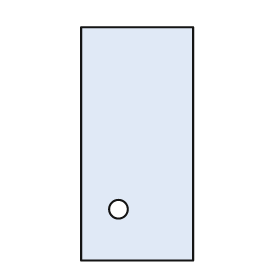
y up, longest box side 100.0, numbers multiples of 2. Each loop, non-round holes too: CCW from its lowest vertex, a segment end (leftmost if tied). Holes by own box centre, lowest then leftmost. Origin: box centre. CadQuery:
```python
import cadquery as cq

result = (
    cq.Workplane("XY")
    .moveTo(-24.0, -50.0)
    .lineTo(24.0, -50.0)
    .lineTo(24.0, 50.0)
    .lineTo(-24.0, 50.0)
    .close()
    .moveTo(-8.0, -28.0)
    .circle(4.0)
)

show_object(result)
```